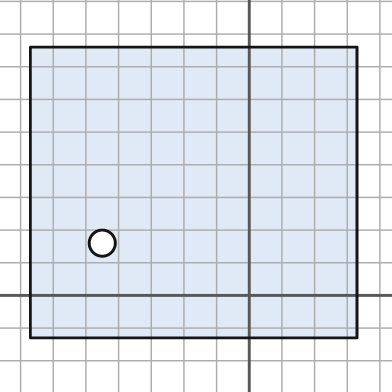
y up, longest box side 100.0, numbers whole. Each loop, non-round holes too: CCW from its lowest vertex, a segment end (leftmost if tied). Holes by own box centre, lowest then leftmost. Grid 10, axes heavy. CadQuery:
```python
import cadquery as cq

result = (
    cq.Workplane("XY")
    .moveTo(-67.0, -13.0)
    .lineTo(33.0, -13.0)
    .lineTo(33.0, 76.0)
    .lineTo(-67.0, 76.0)
    .close()
    .moveTo(-45.0, 16.0)
    .circle(4.0)
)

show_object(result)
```